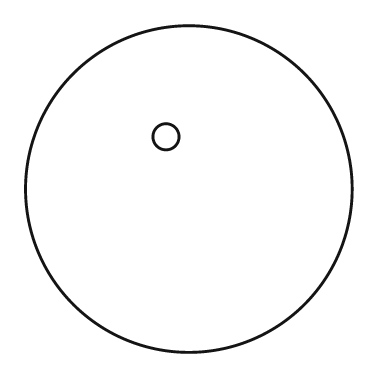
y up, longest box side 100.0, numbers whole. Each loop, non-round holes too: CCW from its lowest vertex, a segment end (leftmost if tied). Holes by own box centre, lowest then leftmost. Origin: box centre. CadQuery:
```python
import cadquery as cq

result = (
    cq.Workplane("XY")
    .moveTo(0.0, 0.0)
    .circle(50.0)
    .moveTo(-7.0, 16.0)
    .circle(4.0)
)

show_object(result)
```